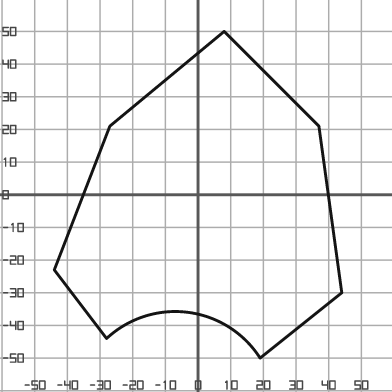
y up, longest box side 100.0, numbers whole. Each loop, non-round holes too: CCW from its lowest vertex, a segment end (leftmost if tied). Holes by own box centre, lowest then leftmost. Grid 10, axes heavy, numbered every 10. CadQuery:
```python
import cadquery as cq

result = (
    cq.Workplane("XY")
    .moveTo(19.0, -50.0)
    .lineTo(44.0, -30.0)
    .lineTo(37.0, 21.0)
    .lineTo(8.0, 50.0)
    .lineTo(-27.0, 21.0)
    .lineTo(-44.0, -23.0)
    .lineTo(-28.0, -44.0)
    .threePointArc((-3.0, -36.0), (19.0, -50.0))
    .close()
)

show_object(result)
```